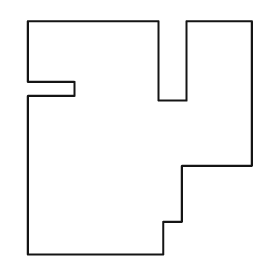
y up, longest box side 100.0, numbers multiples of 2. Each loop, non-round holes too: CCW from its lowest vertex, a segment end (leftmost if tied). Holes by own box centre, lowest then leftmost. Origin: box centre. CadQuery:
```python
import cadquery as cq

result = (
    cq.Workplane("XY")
    .moveTo(-48.0, -50.0)
    .lineTo(10.0, -50.0)
    .lineTo(10.0, -36.0)
    .lineTo(18.0, -36.0)
    .lineTo(18.0, -12.0)
    .lineTo(48.0, -12.0)
    .lineTo(48.0, 50.0)
    .lineTo(20.0, 50.0)
    .lineTo(20.0, 16.0)
    .lineTo(8.0, 16.0)
    .lineTo(8.0, 50.0)
    .lineTo(-48.0, 50.0)
    .lineTo(-48.0, 24.0)
    .lineTo(-28.0, 24.0)
    .lineTo(-28.0, 18.0)
    .lineTo(-48.0, 18.0)
    .close()
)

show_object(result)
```